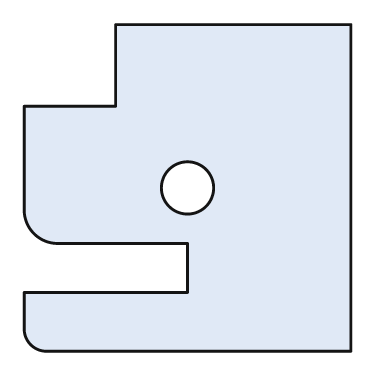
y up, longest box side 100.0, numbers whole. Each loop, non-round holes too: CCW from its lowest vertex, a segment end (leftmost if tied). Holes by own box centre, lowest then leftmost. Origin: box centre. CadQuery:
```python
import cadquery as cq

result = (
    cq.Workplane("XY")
    .moveTo(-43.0, -50.0)
    .lineTo(50.0, -50.0)
    .lineTo(50.0, 50.0)
    .lineTo(-22.0, 50.0)
    .lineTo(-22.0, 25.0)
    .lineTo(-50.0, 25.0)
    .lineTo(-50.0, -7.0)
    .threePointArc((-47.0, -14.0), (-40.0, -17.0))
    .lineTo(0.0, -17.0)
    .lineTo(0.0, -32.0)
    .lineTo(-50.0, -32.0)
    .lineTo(-50.0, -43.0)
    .threePointArc((-48.0, -48.0), (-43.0, -50.0))
    .close()
    .moveTo(0.0, 0.0)
    .circle(8.0)
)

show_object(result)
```